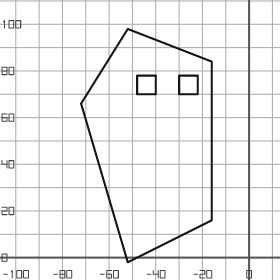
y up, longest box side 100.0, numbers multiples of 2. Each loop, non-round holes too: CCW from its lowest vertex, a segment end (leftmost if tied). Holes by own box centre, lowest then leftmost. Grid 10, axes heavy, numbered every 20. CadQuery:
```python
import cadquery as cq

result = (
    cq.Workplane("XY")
    .moveTo(-52.0, -2.0)
    .lineTo(-16.0, 16.0)
    .lineTo(-16.0, 84.0)
    .lineTo(-52.0, 98.0)
    .lineTo(-72.0, 66.0)
    .close()
    .moveTo(-48.0, 70.0)
    .lineTo(-40.0, 70.0)
    .lineTo(-40.0, 78.0)
    .lineTo(-48.0, 78.0)
    .close()
    .moveTo(-30.0, 70.0)
    .lineTo(-22.0, 70.0)
    .lineTo(-22.0, 78.0)
    .lineTo(-30.0, 78.0)
    .close()
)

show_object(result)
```